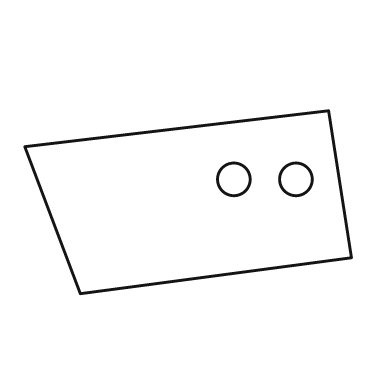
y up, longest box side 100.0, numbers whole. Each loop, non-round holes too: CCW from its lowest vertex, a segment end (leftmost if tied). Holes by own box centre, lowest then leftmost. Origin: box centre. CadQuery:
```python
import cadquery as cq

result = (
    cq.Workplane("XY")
    .moveTo(-33.0, -28.0)
    .lineTo(50.0, -17.0)
    .lineTo(43.0, 28.0)
    .lineTo(-50.0, 17.0)
    .close()
    .moveTo(14.0, 7.0)
    .circle(5.0)
    .moveTo(33.0, 7.0)
    .circle(5.0)
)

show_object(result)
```